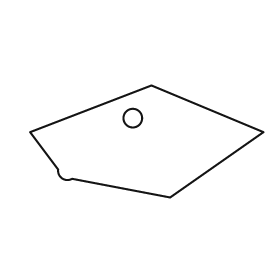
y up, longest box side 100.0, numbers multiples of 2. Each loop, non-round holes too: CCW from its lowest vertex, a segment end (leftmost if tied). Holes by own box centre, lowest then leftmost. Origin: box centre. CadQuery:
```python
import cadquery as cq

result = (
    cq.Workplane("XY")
    .moveTo(10.0, -24.0)
    .lineTo(50.0, 4.0)
    .lineTo(2.0, 24.0)
    .lineTo(-50.0, 4.0)
    .lineTo(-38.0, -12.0)
    .threePointArc((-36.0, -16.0), (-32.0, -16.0))
    .close()
    .moveTo(-6.0, 10.0)
    .circle(4.0)
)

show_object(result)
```